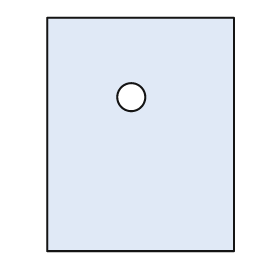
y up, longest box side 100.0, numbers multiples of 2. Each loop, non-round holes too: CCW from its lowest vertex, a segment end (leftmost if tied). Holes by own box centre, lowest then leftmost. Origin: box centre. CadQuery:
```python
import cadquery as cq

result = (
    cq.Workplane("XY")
    .moveTo(-40.0, -50.0)
    .lineTo(40.0, -50.0)
    .lineTo(40.0, 50.0)
    .lineTo(-40.0, 50.0)
    .close()
    .moveTo(-4.0, 16.0)
    .circle(6.0)
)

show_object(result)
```